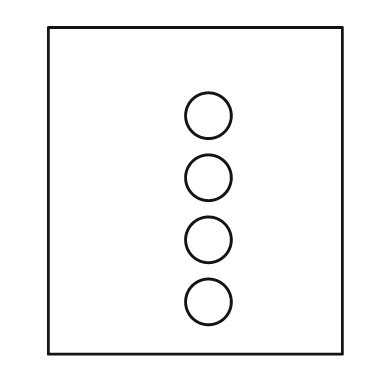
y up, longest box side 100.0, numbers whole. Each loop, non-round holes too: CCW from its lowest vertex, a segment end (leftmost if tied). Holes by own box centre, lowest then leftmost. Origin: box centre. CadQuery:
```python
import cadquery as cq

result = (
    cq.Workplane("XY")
    .moveTo(-45.0, -50.0)
    .lineTo(45.0, -50.0)
    .lineTo(45.0, 50.0)
    .lineTo(-45.0, 50.0)
    .close()
    .moveTo(4.0, -34.0)
    .circle(7.0)
    .moveTo(4.0, -15.0)
    .circle(7.0)
    .moveTo(4.0, 4.0)
    .circle(7.0)
    .moveTo(4.0, 23.0)
    .circle(7.0)
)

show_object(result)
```